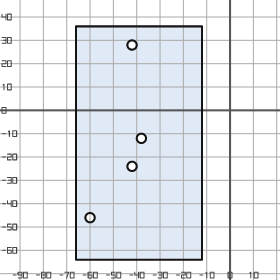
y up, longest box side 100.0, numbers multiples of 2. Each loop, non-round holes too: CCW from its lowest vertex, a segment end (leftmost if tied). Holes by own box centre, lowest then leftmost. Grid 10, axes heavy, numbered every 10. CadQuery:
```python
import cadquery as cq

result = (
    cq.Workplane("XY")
    .moveTo(-66.0, -64.0)
    .lineTo(-12.0, -64.0)
    .lineTo(-12.0, 36.0)
    .lineTo(-66.0, 36.0)
    .close()
    .moveTo(-60.0, -46.0)
    .circle(2.0)
    .moveTo(-42.0, -24.0)
    .circle(2.0)
    .moveTo(-38.0, -12.0)
    .circle(2.0)
    .moveTo(-42.0, 28.0)
    .circle(2.0)
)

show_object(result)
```